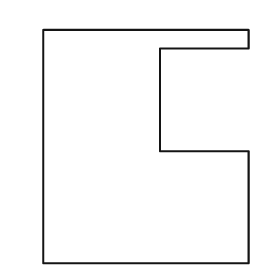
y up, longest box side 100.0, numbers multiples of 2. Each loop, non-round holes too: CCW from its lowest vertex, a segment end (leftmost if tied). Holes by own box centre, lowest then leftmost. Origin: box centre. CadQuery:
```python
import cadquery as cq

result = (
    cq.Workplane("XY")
    .moveTo(-44.0, -50.0)
    .lineTo(44.0, -50.0)
    .lineTo(44.0, -2.0)
    .lineTo(6.0, -2.0)
    .lineTo(6.0, 42.0)
    .lineTo(44.0, 42.0)
    .lineTo(44.0, 50.0)
    .lineTo(-44.0, 50.0)
    .close()
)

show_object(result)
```